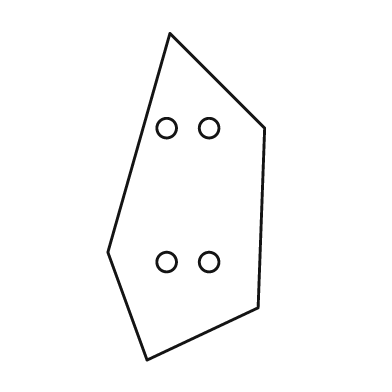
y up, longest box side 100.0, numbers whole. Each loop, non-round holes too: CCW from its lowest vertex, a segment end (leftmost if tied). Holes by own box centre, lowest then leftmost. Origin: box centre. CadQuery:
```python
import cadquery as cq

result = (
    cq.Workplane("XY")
    .moveTo(-12.0, -50.0)
    .lineTo(22.0, -34.0)
    .lineTo(24.0, 21.0)
    .lineTo(-5.0, 50.0)
    .lineTo(-24.0, -17.0)
    .close()
    .moveTo(-6.0, -20.0)
    .circle(3.0)
    .moveTo(7.0, -20.0)
    .circle(3.0)
    .moveTo(-6.0, 21.0)
    .circle(3.0)
    .moveTo(7.0, 21.0)
    .circle(3.0)
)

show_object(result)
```